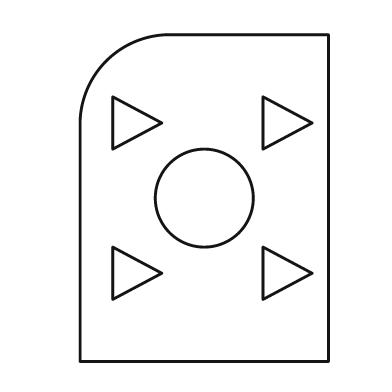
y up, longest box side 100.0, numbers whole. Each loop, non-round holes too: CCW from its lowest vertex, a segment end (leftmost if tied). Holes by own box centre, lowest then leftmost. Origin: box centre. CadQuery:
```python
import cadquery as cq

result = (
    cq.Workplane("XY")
    .moveTo(-38.0, -50.0)
    .lineTo(38.0, -50.0)
    .lineTo(38.0, 50.0)
    .lineTo(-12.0, 50.0)
    .threePointArc((-30.0, 42.0), (-38.0, 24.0))
    .close()
    .moveTo(-28.0, -31.0)
    .lineTo(-13.0, -23.0)
    .lineTo(-28.0, -15.0)
    .close()
    .moveTo(18.0, -31.0)
    .lineTo(33.0, -23.0)
    .lineTo(18.0, -15.0)
    .close()
    .moveTo(0.0, 0.0)
    .circle(15.0)
    .moveTo(-28.0, 15.0)
    .lineTo(-13.0, 23.0)
    .lineTo(-28.0, 31.0)
    .close()
    .moveTo(18.0, 15.0)
    .lineTo(33.0, 23.0)
    .lineTo(18.0, 31.0)
    .close()
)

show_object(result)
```